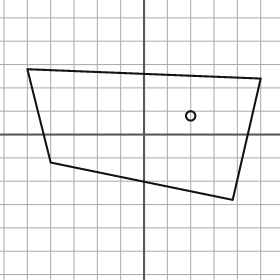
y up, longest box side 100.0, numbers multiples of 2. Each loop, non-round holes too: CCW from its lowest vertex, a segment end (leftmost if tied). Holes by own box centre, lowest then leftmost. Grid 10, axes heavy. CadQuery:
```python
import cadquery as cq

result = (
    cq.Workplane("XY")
    .moveTo(38.0, -28.0)
    .lineTo(50.0, 24.0)
    .lineTo(-50.0, 28.0)
    .lineTo(-40.0, -12.0)
    .close()
    .moveTo(20.0, 8.0)
    .circle(2.0)
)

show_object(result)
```